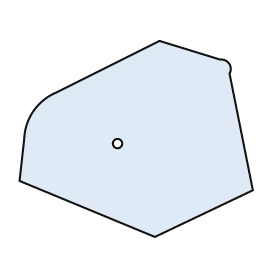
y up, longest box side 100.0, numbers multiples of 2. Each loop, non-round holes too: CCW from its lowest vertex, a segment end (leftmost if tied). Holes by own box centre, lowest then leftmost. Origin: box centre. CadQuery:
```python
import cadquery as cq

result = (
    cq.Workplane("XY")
    .moveTo(8.0, -42.0)
    .lineTo(50.0, -22.0)
    .lineTo(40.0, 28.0)
    .threePointArc((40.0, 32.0), (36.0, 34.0))
    .lineTo(10.0, 42.0)
    .lineTo(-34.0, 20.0)
    .threePointArc((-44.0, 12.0), (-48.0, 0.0))
    .lineTo(-50.0, -18.0)
    .close()
    .moveTo(-8.0, -2.0)
    .circle(2.0)
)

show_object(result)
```